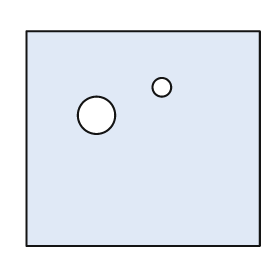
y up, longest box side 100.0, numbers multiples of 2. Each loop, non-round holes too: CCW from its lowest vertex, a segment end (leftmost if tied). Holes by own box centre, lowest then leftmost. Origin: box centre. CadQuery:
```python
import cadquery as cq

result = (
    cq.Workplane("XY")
    .moveTo(-50.0, -46.0)
    .lineTo(50.0, -46.0)
    .lineTo(50.0, 46.0)
    .lineTo(-50.0, 46.0)
    .close()
    .moveTo(-20.0, 10.0)
    .circle(8.0)
    .moveTo(8.0, 22.0)
    .circle(4.0)
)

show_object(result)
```